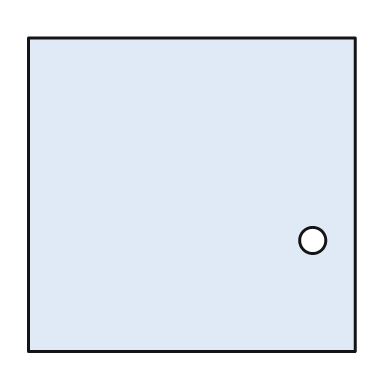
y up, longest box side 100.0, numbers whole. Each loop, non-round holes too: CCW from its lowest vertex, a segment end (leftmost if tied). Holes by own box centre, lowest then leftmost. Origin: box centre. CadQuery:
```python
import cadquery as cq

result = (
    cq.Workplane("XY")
    .moveTo(-50.0, -48.0)
    .lineTo(50.0, -48.0)
    .lineTo(50.0, 48.0)
    .lineTo(-50.0, 48.0)
    .close()
    .moveTo(37.0, -14.0)
    .circle(4.0)
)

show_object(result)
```